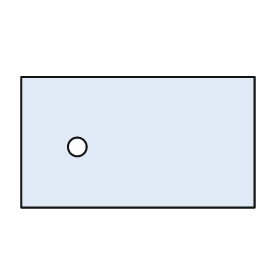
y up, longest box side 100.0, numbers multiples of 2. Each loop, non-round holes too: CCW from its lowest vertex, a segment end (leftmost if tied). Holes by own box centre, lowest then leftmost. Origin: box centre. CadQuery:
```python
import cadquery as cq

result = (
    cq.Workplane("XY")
    .moveTo(-50.0, -28.0)
    .lineTo(50.0, -28.0)
    .lineTo(50.0, 28.0)
    .lineTo(-50.0, 28.0)
    .close()
    .moveTo(-26.0, -2.0)
    .circle(4.0)
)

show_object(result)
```